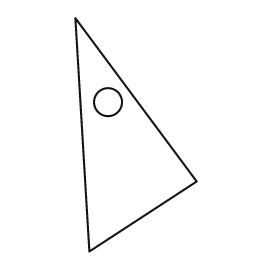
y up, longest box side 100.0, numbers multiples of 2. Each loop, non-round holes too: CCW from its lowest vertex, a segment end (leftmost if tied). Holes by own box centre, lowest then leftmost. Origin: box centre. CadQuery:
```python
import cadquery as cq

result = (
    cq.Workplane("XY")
    .moveTo(-20.0, -50.0)
    .lineTo(26.0, -20.0)
    .lineTo(-26.0, 50.0)
    .close()
    .moveTo(-12.0, 14.0)
    .circle(6.0)
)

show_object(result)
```